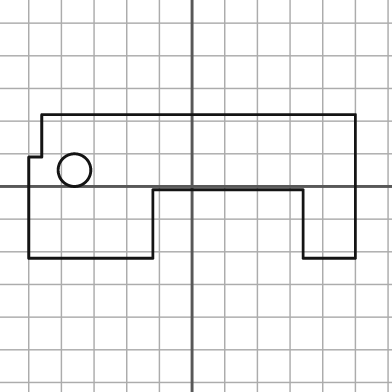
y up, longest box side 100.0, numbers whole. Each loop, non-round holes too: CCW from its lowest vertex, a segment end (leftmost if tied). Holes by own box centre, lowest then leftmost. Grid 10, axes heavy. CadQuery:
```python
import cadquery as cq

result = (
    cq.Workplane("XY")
    .moveTo(-50.0, -22.0)
    .lineTo(-12.0, -22.0)
    .lineTo(-12.0, -1.0)
    .lineTo(34.0, -1.0)
    .lineTo(34.0, -22.0)
    .lineTo(50.0, -22.0)
    .lineTo(50.0, 22.0)
    .lineTo(-46.0, 22.0)
    .lineTo(-46.0, 9.0)
    .lineTo(-50.0, 9.0)
    .close()
    .moveTo(-36.0, 5.0)
    .circle(5.0)
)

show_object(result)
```